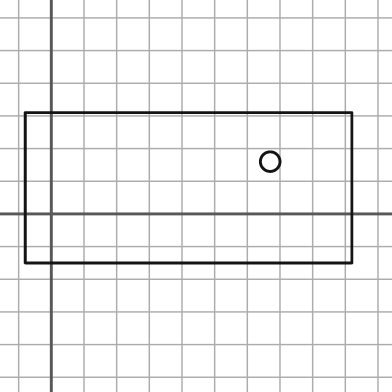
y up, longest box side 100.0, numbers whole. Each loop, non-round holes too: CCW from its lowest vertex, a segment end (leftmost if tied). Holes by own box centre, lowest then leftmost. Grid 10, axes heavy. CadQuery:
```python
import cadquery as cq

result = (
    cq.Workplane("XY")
    .moveTo(-8.0, -15.0)
    .lineTo(92.0, -15.0)
    .lineTo(92.0, 31.0)
    .lineTo(-8.0, 31.0)
    .close()
    .moveTo(67.0, 16.0)
    .circle(3.0)
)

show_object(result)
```